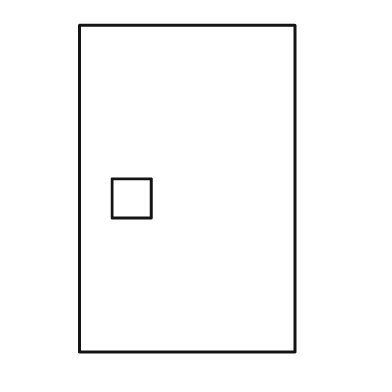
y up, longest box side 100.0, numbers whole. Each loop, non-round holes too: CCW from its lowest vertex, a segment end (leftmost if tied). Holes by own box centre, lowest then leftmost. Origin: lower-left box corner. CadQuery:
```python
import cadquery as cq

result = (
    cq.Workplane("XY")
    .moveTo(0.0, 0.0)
    .lineTo(66.0, 0.0)
    .lineTo(66.0, 100.0)
    .lineTo(0.0, 100.0)
    .close()
    .moveTo(10.0, 41.0)
    .lineTo(22.0, 41.0)
    .lineTo(22.0, 53.0)
    .lineTo(10.0, 53.0)
    .close()
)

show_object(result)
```